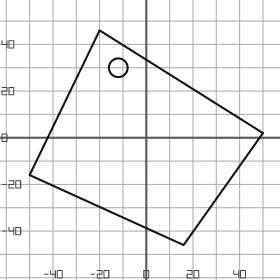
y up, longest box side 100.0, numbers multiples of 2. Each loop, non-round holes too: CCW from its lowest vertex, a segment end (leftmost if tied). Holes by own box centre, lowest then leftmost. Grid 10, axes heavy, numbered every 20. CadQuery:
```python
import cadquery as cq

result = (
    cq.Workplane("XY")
    .moveTo(16.0, -46.0)
    .lineTo(50.0, 2.0)
    .lineTo(-20.0, 46.0)
    .lineTo(-50.0, -16.0)
    .close()
    .moveTo(-12.0, 30.0)
    .circle(4.0)
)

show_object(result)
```